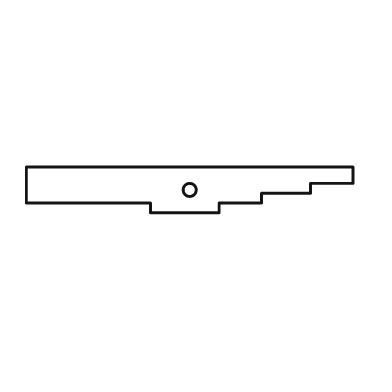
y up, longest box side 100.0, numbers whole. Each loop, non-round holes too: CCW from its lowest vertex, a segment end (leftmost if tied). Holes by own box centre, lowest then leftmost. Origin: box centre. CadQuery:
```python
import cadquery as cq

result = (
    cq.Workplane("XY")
    .moveTo(-12.0, -7.0)
    .lineTo(9.0, -7.0)
    .lineTo(9.0, -4.0)
    .lineTo(22.0, -4.0)
    .lineTo(22.0, -1.0)
    .lineTo(37.0, -1.0)
    .lineTo(37.0, 2.0)
    .lineTo(50.0, 2.0)
    .lineTo(50.0, 7.0)
    .lineTo(-50.0, 7.0)
    .lineTo(-50.0, -4.0)
    .lineTo(-12.0, -4.0)
    .close()
    .moveTo(0.0, 0.0)
    .circle(2.0)
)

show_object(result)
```